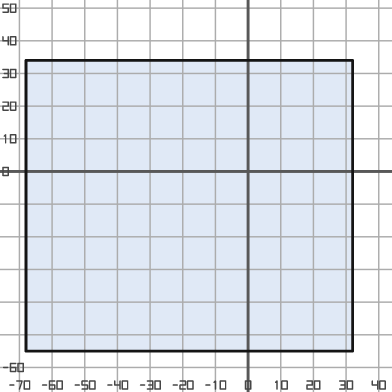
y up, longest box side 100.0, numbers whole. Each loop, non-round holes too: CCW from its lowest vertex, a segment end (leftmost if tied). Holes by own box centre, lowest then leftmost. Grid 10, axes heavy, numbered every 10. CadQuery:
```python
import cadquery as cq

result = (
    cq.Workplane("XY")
    .moveTo(-68.0, -55.0)
    .lineTo(32.0, -55.0)
    .lineTo(32.0, 34.0)
    .lineTo(-68.0, 34.0)
    .close()
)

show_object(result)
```